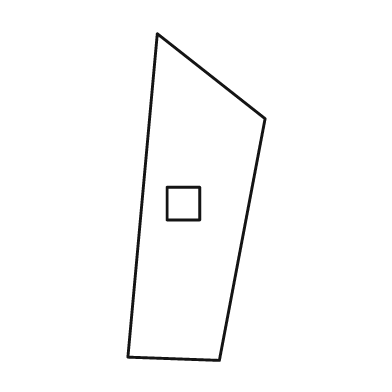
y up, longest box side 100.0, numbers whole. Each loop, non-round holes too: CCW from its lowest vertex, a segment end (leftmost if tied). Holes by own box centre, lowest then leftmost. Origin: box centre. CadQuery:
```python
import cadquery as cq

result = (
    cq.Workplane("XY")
    .moveTo(7.0, -50.0)
    .lineTo(21.0, 24.0)
    .lineTo(-12.0, 50.0)
    .lineTo(-21.0, -49.0)
    .close()
    .moveTo(-9.0, -7.0)
    .lineTo(1.0, -7.0)
    .lineTo(1.0, 3.0)
    .lineTo(-9.0, 3.0)
    .close()
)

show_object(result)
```